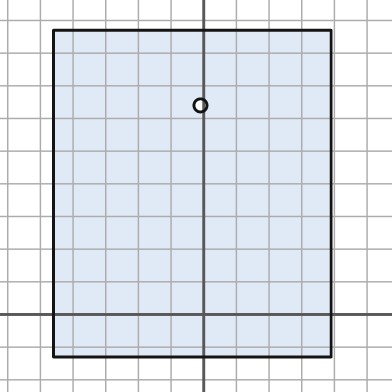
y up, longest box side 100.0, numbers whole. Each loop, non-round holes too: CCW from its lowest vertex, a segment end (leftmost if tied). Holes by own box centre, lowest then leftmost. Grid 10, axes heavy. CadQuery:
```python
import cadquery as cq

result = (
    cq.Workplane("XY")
    .moveTo(-46.0, -13.0)
    .lineTo(39.0, -13.0)
    .lineTo(39.0, 87.0)
    .lineTo(-46.0, 87.0)
    .close()
    .moveTo(-1.0, 64.0)
    .circle(2.0)
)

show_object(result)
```